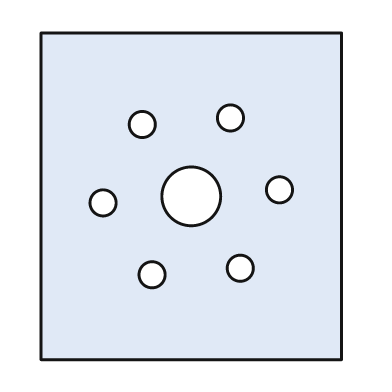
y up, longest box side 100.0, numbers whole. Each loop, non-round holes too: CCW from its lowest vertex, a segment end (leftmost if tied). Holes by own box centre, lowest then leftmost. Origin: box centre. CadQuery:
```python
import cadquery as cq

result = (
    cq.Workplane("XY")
    .moveTo(-46.0, -50.0)
    .lineTo(46.0, -50.0)
    .lineTo(46.0, 50.0)
    .lineTo(-46.0, 50.0)
    .close()
    .moveTo(-12.0, -24.0)
    .circle(4.0)
    .moveTo(15.0, -22.0)
    .circle(4.0)
    .moveTo(-27.0, -2.0)
    .circle(4.0)
    .moveTo(0.0, 0.0)
    .circle(9.0)
    .moveTo(27.0, 2.0)
    .circle(4.0)
    .moveTo(-15.0, 22.0)
    .circle(4.0)
    .moveTo(12.0, 24.0)
    .circle(4.0)
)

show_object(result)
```